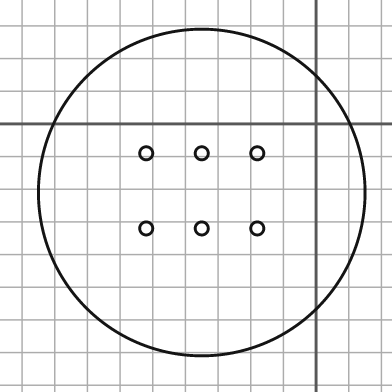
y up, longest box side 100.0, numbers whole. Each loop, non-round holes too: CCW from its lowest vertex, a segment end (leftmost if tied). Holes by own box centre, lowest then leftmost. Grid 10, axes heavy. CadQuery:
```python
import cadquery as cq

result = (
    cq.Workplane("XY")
    .moveTo(-35.0, -21.0)
    .circle(50.0)
    .moveTo(-52.0, -32.0)
    .circle(2.0)
    .moveTo(-35.0, -32.0)
    .circle(2.0)
    .moveTo(-18.0, -32.0)
    .circle(2.0)
    .moveTo(-52.0, -9.0)
    .circle(2.0)
    .moveTo(-35.0, -9.0)
    .circle(2.0)
    .moveTo(-18.0, -9.0)
    .circle(2.0)
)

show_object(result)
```